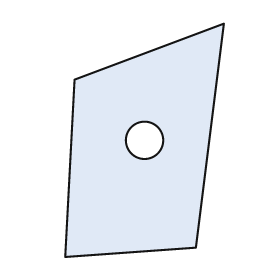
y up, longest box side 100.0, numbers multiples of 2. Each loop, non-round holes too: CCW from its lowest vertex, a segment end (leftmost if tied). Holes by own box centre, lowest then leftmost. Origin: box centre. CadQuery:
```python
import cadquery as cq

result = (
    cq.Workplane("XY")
    .moveTo(-34.0, -50.0)
    .lineTo(22.0, -46.0)
    .lineTo(34.0, 50.0)
    .lineTo(-30.0, 26.0)
    .close()
    .moveTo(0.0, 0.0)
    .circle(8.0)
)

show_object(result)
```